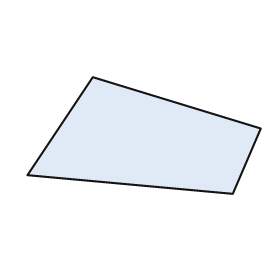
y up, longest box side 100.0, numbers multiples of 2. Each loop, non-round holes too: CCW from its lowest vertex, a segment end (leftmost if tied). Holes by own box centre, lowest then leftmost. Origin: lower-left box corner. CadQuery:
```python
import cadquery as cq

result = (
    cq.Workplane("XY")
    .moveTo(88.0, 0.0)
    .lineTo(100.0, 28.0)
    .lineTo(28.0, 50.0)
    .lineTo(0.0, 8.0)
    .close()
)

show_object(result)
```